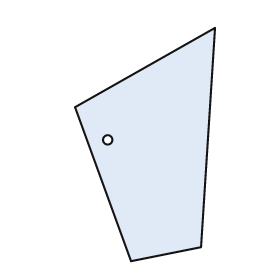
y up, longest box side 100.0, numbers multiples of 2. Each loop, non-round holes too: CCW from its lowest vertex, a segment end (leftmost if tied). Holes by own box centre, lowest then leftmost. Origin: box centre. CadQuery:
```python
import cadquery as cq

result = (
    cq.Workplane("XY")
    .moveTo(-6.0, -50.0)
    .lineTo(24.0, -44.0)
    .lineTo(30.0, 50.0)
    .lineTo(-30.0, 16.0)
    .close()
    .moveTo(-16.0, 2.0)
    .circle(2.0)
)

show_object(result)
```